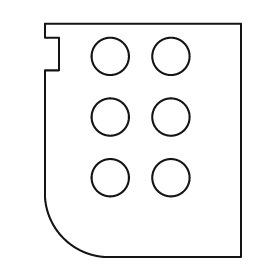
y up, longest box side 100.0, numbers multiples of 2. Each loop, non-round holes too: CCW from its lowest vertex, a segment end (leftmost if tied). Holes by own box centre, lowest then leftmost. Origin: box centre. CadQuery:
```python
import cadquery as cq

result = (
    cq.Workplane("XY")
    .moveTo(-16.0, -50.0)
    .lineTo(42.0, -50.0)
    .lineTo(42.0, 50.0)
    .lineTo(-42.0, 50.0)
    .lineTo(-42.0, 44.0)
    .lineTo(-36.0, 44.0)
    .lineTo(-36.0, 30.0)
    .lineTo(-42.0, 30.0)
    .lineTo(-42.0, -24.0)
    .threePointArc((-34.0, -42.0), (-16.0, -50.0))
    .close()
    .moveTo(-14.0, -16.0)
    .circle(8.0)
    .moveTo(12.0, -16.0)
    .circle(8.0)
    .moveTo(-14.0, 10.0)
    .circle(8.0)
    .moveTo(12.0, 10.0)
    .circle(8.0)
    .moveTo(-14.0, 36.0)
    .circle(8.0)
    .moveTo(12.0, 36.0)
    .circle(8.0)
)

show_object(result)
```